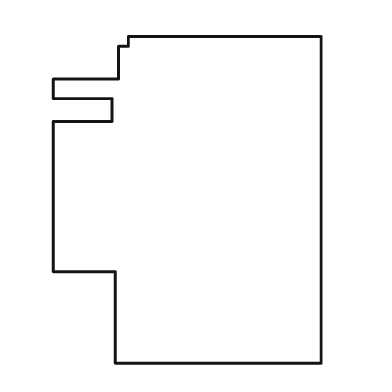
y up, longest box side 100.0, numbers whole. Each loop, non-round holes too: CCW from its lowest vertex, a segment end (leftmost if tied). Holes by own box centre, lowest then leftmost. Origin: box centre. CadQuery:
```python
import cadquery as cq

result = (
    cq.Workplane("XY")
    .moveTo(-22.0, -50.0)
    .lineTo(41.0, -50.0)
    .lineTo(41.0, 50.0)
    .lineTo(-18.0, 50.0)
    .lineTo(-18.0, 47.0)
    .lineTo(-21.0, 47.0)
    .lineTo(-21.0, 37.0)
    .lineTo(-41.0, 37.0)
    .lineTo(-41.0, 31.0)
    .lineTo(-23.0, 31.0)
    .lineTo(-23.0, 24.0)
    .lineTo(-41.0, 24.0)
    .lineTo(-41.0, -22.0)
    .lineTo(-22.0, -22.0)
    .close()
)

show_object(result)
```